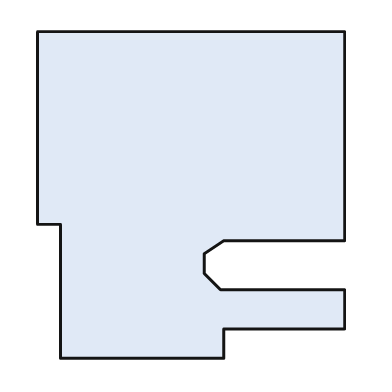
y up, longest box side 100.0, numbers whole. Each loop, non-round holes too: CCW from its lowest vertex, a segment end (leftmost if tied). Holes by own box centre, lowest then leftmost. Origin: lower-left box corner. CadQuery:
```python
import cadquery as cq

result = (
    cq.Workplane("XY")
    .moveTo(7.0, 0.0)
    .lineTo(57.0, 0.0)
    .lineTo(57.0, 9.0)
    .lineTo(94.0, 9.0)
    .lineTo(94.0, 21.0)
    .lineTo(56.0, 21.0)
    .lineTo(51.0, 26.0)
    .lineTo(51.0, 32.0)
    .lineTo(57.0, 36.0)
    .lineTo(94.0, 36.0)
    .lineTo(94.0, 100.0)
    .lineTo(0.0, 100.0)
    .lineTo(0.0, 41.0)
    .lineTo(7.0, 41.0)
    .close()
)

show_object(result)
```